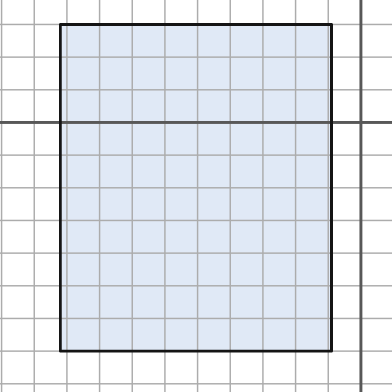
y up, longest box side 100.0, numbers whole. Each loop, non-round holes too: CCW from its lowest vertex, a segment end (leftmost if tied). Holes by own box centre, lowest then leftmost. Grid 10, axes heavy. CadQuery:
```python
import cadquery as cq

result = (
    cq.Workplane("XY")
    .moveTo(-92.0, -70.0)
    .lineTo(-9.0, -70.0)
    .lineTo(-9.0, 30.0)
    .lineTo(-92.0, 30.0)
    .close()
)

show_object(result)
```